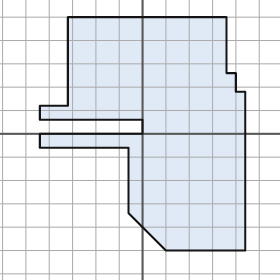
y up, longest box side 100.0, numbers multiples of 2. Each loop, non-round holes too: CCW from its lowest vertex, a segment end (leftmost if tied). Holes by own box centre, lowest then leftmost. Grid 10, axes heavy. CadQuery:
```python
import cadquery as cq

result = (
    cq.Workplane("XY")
    .moveTo(10.0, -50.0)
    .lineTo(44.0, -50.0)
    .lineTo(44.0, 18.0)
    .lineTo(40.0, 18.0)
    .lineTo(40.0, 26.0)
    .lineTo(36.0, 26.0)
    .lineTo(36.0, 50.0)
    .lineTo(-32.0, 50.0)
    .lineTo(-32.0, 12.0)
    .lineTo(-44.0, 12.0)
    .lineTo(-44.0, 6.0)
    .lineTo(0.0, 6.0)
    .lineTo(0.0, 0.0)
    .lineTo(-44.0, 0.0)
    .lineTo(-44.0, -6.0)
    .lineTo(-6.0, -6.0)
    .lineTo(-6.0, -34.0)
    .close()
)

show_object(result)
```